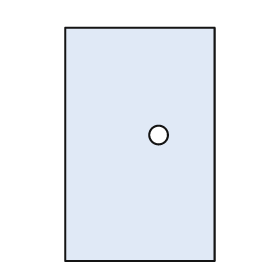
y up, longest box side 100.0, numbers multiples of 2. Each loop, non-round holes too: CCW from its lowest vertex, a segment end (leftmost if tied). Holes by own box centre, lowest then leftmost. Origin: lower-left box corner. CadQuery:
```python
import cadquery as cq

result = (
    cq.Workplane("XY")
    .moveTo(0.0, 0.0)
    .lineTo(64.0, 0.0)
    .lineTo(64.0, 100.0)
    .lineTo(0.0, 100.0)
    .close()
    .moveTo(40.0, 54.0)
    .circle(4.0)
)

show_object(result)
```